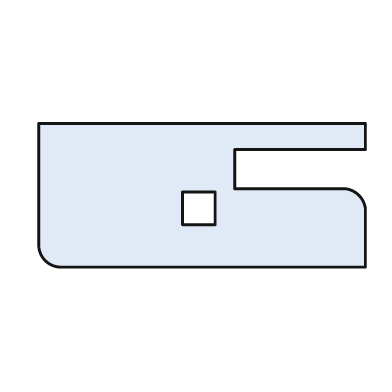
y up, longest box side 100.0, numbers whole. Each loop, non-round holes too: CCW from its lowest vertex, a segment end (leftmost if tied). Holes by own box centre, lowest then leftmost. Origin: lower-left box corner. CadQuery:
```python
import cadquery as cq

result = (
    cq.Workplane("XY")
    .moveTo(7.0, 0.0)
    .lineTo(100.0, 0.0)
    .lineTo(100.0, 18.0)
    .threePointArc((98.0, 22.0), (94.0, 24.0))
    .lineTo(60.0, 24.0)
    .lineTo(60.0, 36.0)
    .lineTo(100.0, 36.0)
    .lineTo(100.0, 44.0)
    .lineTo(0.0, 44.0)
    .lineTo(0.0, 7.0)
    .threePointArc((2.0, 2.0), (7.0, 0.0))
    .close()
    .moveTo(44.0, 13.0)
    .lineTo(54.0, 13.0)
    .lineTo(54.0, 23.0)
    .lineTo(44.0, 23.0)
    .close()
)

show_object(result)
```